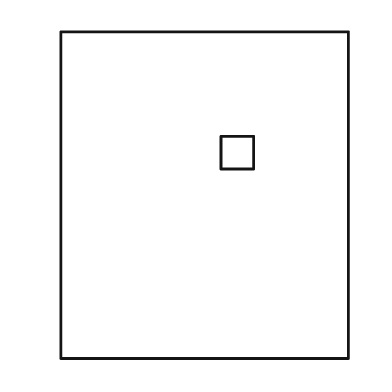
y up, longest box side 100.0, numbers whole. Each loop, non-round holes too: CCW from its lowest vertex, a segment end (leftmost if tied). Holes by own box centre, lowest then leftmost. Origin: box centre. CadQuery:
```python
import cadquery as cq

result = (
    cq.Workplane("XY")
    .moveTo(-44.0, -50.0)
    .lineTo(44.0, -50.0)
    .lineTo(44.0, 50.0)
    .lineTo(-44.0, 50.0)
    .close()
    .moveTo(5.0, 8.0)
    .lineTo(15.0, 8.0)
    .lineTo(15.0, 18.0)
    .lineTo(5.0, 18.0)
    .close()
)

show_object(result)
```